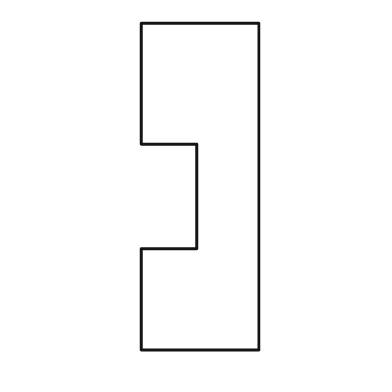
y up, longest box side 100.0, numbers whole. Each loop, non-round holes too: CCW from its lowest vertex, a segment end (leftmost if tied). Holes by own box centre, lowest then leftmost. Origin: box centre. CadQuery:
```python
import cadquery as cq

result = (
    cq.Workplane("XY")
    .moveTo(-18.0, -50.0)
    .lineTo(18.0, -50.0)
    .lineTo(18.0, 50.0)
    .lineTo(-18.0, 50.0)
    .lineTo(-18.0, 13.0)
    .lineTo(-1.0, 13.0)
    .lineTo(-1.0, -19.0)
    .lineTo(-18.0, -19.0)
    .close()
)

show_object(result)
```